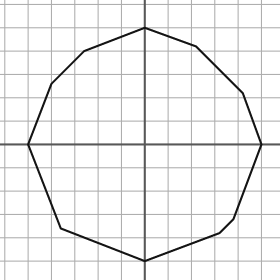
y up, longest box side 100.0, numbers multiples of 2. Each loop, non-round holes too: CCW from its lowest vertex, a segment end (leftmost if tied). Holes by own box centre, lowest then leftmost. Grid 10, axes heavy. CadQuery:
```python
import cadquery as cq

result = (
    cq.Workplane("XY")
    .moveTo(0.0, -50.0)
    .lineTo(32.0, -38.0)
    .lineTo(38.0, -32.0)
    .lineTo(50.0, 0.0)
    .lineTo(42.0, 22.0)
    .lineTo(22.0, 42.0)
    .lineTo(0.0, 50.0)
    .lineTo(-26.0, 40.0)
    .lineTo(-40.0, 26.0)
    .lineTo(-50.0, 0.0)
    .lineTo(-36.0, -36.0)
    .close()
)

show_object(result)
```